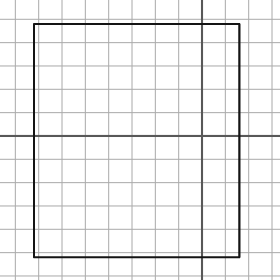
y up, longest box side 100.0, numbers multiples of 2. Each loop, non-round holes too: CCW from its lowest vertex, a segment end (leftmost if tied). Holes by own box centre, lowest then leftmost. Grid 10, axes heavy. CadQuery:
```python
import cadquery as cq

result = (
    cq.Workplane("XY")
    .moveTo(-72.0, -52.0)
    .lineTo(16.0, -52.0)
    .lineTo(16.0, 48.0)
    .lineTo(-72.0, 48.0)
    .close()
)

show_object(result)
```